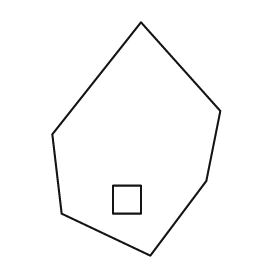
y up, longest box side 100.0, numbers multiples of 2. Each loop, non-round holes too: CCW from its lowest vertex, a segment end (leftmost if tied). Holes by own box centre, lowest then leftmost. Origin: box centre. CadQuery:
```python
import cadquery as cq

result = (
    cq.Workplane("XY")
    .moveTo(6.0, -50.0)
    .lineTo(30.0, -18.0)
    .lineTo(36.0, 12.0)
    .lineTo(2.0, 50.0)
    .lineTo(-36.0, 2.0)
    .lineTo(-32.0, -32.0)
    .close()
    .moveTo(-10.0, -32.0)
    .lineTo(2.0, -32.0)
    .lineTo(2.0, -20.0)
    .lineTo(-10.0, -20.0)
    .close()
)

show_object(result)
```